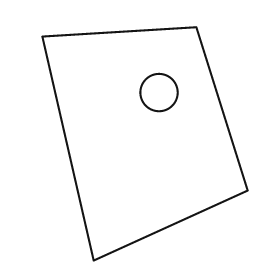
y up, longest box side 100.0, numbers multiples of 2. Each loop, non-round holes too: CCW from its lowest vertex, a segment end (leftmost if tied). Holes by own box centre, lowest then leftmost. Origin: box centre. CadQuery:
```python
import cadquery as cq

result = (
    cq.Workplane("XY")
    .moveTo(-22.0, -50.0)
    .lineTo(44.0, -20.0)
    .lineTo(22.0, 50.0)
    .lineTo(-44.0, 46.0)
    .close()
    .moveTo(6.0, 22.0)
    .circle(8.0)
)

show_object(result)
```